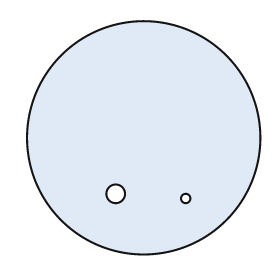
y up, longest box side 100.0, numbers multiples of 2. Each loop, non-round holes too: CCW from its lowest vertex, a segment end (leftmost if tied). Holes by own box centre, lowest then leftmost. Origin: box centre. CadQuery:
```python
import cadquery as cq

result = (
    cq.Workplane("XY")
    .moveTo(0.0, 0.0)
    .circle(50.0)
    .moveTo(18.0, -26.0)
    .circle(2.0)
    .moveTo(-12.0, -24.0)
    .circle(4.0)
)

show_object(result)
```